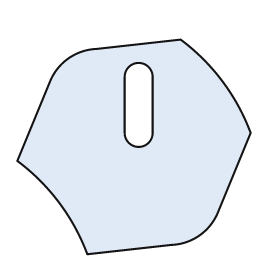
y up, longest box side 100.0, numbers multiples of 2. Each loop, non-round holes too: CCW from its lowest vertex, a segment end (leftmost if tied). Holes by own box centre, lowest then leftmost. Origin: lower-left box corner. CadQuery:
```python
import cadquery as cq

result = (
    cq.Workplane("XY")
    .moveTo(30.0, 0.0)
    .lineTo(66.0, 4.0)
    .threePointArc((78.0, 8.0), (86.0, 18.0))
    .lineTo(100.0, 52.0)
    .threePointArc((88.0, 74.0), (70.0, 92.0))
    .lineTo(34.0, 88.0)
    .threePointArc((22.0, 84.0), (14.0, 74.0))
    .lineTo(0.0, 40.0)
    .threePointArc((18.0, 22.0), (30.0, 0.0))
    .close()
    .moveTo(46.0, 52.0)
    .threePointArc((52.0, 46.0), (58.0, 52.0))
    .lineTo(58.0, 76.0)
    .threePointArc((52.0, 82.0), (46.0, 76.0))
    .close()
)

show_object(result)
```